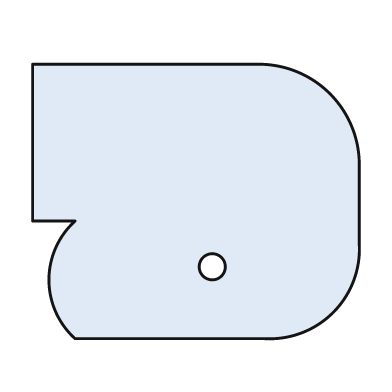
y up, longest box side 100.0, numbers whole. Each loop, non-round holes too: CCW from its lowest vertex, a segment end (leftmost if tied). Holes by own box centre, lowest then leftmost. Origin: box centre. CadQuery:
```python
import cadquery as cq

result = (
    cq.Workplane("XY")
    .moveTo(-37.0, -42.0)
    .lineTo(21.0, -42.0)
    .threePointArc((42.0, -34.0), (50.0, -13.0))
    .lineTo(50.0, 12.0)
    .threePointArc((41.0, 33.0), (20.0, 42.0))
    .lineTo(-50.0, 42.0)
    .lineTo(-50.0, -6.0)
    .lineTo(-37.0, -6.0)
    .threePointArc((-45.0, -24.0), (-37.0, -42.0))
    .close()
    .moveTo(5.0, -20.0)
    .circle(4.0)
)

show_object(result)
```